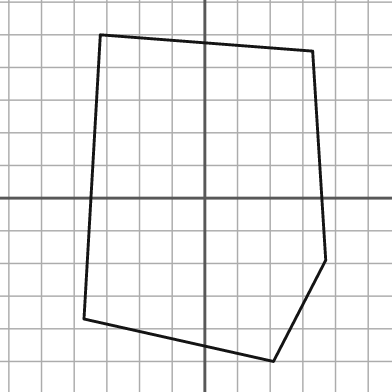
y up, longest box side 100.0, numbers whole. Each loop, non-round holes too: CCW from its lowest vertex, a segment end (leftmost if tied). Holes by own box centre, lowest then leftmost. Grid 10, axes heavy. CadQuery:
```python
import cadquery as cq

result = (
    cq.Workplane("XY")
    .moveTo(21.0, -50.0)
    .lineTo(37.0, -19.0)
    .lineTo(33.0, 45.0)
    .lineTo(-32.0, 50.0)
    .lineTo(-37.0, -37.0)
    .close()
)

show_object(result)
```